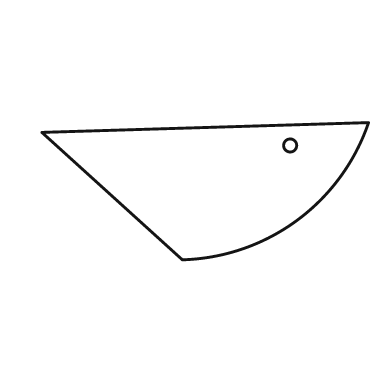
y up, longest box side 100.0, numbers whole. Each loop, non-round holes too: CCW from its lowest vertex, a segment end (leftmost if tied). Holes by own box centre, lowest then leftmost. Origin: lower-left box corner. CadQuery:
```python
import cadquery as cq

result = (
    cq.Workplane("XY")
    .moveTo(43.0, 0.0)
    .threePointArc((78.0, 12.0), (100.0, 42.0))
    .lineTo(0.0, 39.0)
    .close()
    .moveTo(76.0, 35.0)
    .circle(2.0)
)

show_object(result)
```